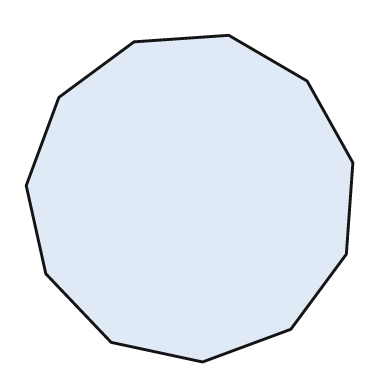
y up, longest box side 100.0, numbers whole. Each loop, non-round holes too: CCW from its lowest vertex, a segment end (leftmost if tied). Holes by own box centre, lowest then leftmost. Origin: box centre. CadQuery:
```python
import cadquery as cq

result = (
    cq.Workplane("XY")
    .moveTo(4.0, -50.0)
    .lineTo(31.0, -40.0)
    .lineTo(48.0, -17.0)
    .lineTo(50.0, 11.0)
    .lineTo(36.0, 36.0)
    .lineTo(12.0, 50.0)
    .lineTo(-17.0, 48.0)
    .lineTo(-40.0, 31.0)
    .lineTo(-50.0, 4.0)
    .lineTo(-44.0, -23.0)
    .lineTo(-24.0, -44.0)
    .close()
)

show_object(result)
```